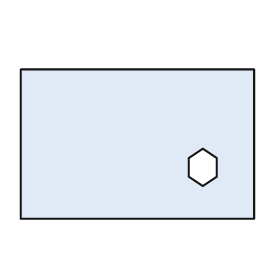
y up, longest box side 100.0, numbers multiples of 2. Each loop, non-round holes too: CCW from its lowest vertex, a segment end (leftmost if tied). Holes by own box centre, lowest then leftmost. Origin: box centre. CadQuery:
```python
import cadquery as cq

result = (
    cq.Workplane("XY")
    .moveTo(-50.0, -32.0)
    .lineTo(50.0, -32.0)
    .lineTo(50.0, 32.0)
    .lineTo(-50.0, 32.0)
    .close()
    .moveTo(28.0, -18.0)
    .lineTo(34.0, -14.0)
    .lineTo(34.0, -6.0)
    .lineTo(28.0, -2.0)
    .lineTo(22.0, -6.0)
    .lineTo(22.0, -14.0)
    .close()
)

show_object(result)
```